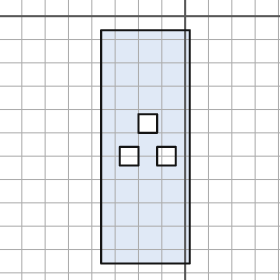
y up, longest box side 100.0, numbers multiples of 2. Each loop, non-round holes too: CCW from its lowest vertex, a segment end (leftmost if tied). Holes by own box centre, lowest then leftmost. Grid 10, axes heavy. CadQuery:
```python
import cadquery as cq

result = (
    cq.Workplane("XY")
    .moveTo(-36.0, -106.0)
    .lineTo(2.0, -106.0)
    .lineTo(2.0, -6.0)
    .lineTo(-36.0, -6.0)
    .close()
    .moveTo(-28.0, -64.0)
    .lineTo(-20.0, -64.0)
    .lineTo(-20.0, -56.0)
    .lineTo(-28.0, -56.0)
    .close()
    .moveTo(-12.0, -64.0)
    .lineTo(-4.0, -64.0)
    .lineTo(-4.0, -56.0)
    .lineTo(-12.0, -56.0)
    .close()
    .moveTo(-20.0, -50.0)
    .lineTo(-12.0, -50.0)
    .lineTo(-12.0, -42.0)
    .lineTo(-20.0, -42.0)
    .close()
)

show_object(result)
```